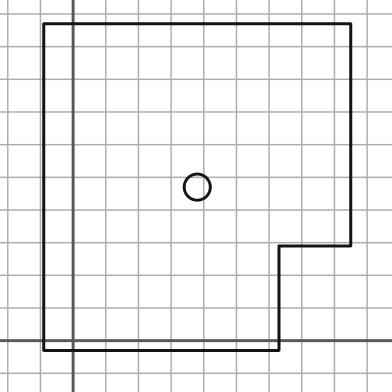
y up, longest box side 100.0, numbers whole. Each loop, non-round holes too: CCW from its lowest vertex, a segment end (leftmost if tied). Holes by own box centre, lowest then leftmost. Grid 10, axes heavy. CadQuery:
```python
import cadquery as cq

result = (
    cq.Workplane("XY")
    .moveTo(-9.0, -3.0)
    .lineTo(63.0, -3.0)
    .lineTo(63.0, 29.0)
    .lineTo(85.0, 29.0)
    .lineTo(85.0, 97.0)
    .lineTo(-9.0, 97.0)
    .close()
    .moveTo(38.0, 47.0)
    .circle(4.0)
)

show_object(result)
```